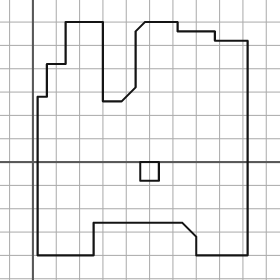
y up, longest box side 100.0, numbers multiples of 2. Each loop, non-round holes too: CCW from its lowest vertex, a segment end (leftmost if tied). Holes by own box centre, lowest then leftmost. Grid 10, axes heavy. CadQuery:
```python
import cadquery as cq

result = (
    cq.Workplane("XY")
    .moveTo(2.0, -40.0)
    .lineTo(26.0, -40.0)
    .lineTo(26.0, -26.0)
    .lineTo(64.0, -26.0)
    .lineTo(70.0, -32.0)
    .lineTo(70.0, -40.0)
    .lineTo(92.0, -40.0)
    .lineTo(92.0, 52.0)
    .lineTo(78.0, 52.0)
    .lineTo(78.0, 56.0)
    .lineTo(62.0, 56.0)
    .lineTo(62.0, 60.0)
    .lineTo(48.0, 60.0)
    .lineTo(44.0, 56.0)
    .lineTo(44.0, 32.0)
    .lineTo(38.0, 26.0)
    .lineTo(30.0, 26.0)
    .lineTo(30.0, 60.0)
    .lineTo(14.0, 60.0)
    .lineTo(14.0, 42.0)
    .lineTo(6.0, 42.0)
    .lineTo(6.0, 28.0)
    .lineTo(2.0, 28.0)
    .close()
    .moveTo(46.0, -8.0)
    .lineTo(54.0, -8.0)
    .lineTo(54.0, 0.0)
    .lineTo(46.0, 0.0)
    .close()
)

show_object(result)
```